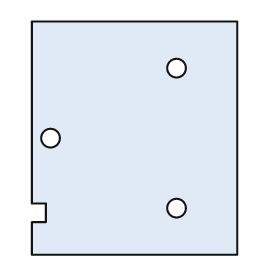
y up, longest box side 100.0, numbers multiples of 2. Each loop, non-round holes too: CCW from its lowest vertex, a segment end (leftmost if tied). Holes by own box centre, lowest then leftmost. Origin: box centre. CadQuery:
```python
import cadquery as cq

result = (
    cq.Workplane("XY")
    .moveTo(-44.0, -50.0)
    .lineTo(44.0, -50.0)
    .lineTo(44.0, 50.0)
    .lineTo(-44.0, 50.0)
    .lineTo(-44.0, -28.0)
    .lineTo(-38.0, -28.0)
    .lineTo(-38.0, -36.0)
    .lineTo(-44.0, -36.0)
    .close()
    .moveTo(18.0, -30.0)
    .circle(4.0)
    .moveTo(-36.0, 0.0)
    .circle(4.0)
    .moveTo(18.0, 30.0)
    .circle(4.0)
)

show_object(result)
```